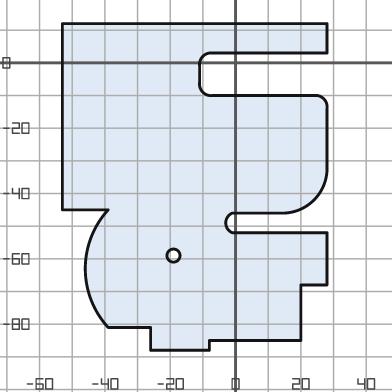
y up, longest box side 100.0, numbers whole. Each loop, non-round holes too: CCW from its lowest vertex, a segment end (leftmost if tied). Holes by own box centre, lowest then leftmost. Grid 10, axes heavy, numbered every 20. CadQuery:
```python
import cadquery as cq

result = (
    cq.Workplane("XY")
    .moveTo(-26.0, -88.0)
    .lineTo(-8.0, -88.0)
    .lineTo(-8.0, -85.0)
    .lineTo(20.0, -85.0)
    .lineTo(20.0, -68.0)
    .lineTo(28.0, -68.0)
    .lineTo(28.0, -52.0)
    .lineTo(-1.0, -52.0)
    .threePointArc((-3.0, -49.0), (-1.0, -46.0))
    .lineTo(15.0, -46.0)
    .threePointArc((24.0, -42.0), (28.0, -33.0))
    .lineTo(28.0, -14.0)
    .threePointArc((27.0, -11.0), (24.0, -10.0))
    .lineTo(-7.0, -10.0)
    .threePointArc((-10.0, -9.0), (-11.0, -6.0))
    .lineTo(-11.0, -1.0)
    .threePointArc((-10.0, 2.0), (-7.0, 3.0))
    .lineTo(28.0, 3.0)
    .lineTo(28.0, 12.0)
    .lineTo(-53.0, 12.0)
    .lineTo(-53.0, -45.0)
    .lineTo(-39.0, -45.0)
    .threePointArc((-46.0, -63.0), (-39.0, -81.0))
    .lineTo(-26.0, -81.0)
    .close()
    .moveTo(-19.0, -59.0)
    .circle(2.0)
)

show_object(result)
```